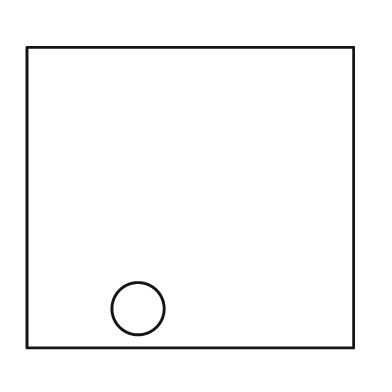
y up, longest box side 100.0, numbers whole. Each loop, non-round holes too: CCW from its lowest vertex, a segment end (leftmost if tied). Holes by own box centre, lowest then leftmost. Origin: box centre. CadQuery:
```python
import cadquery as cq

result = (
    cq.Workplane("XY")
    .moveTo(-50.0, -46.0)
    .lineTo(50.0, -46.0)
    .lineTo(50.0, 46.0)
    .lineTo(-50.0, 46.0)
    .close()
    .moveTo(-16.0, -34.0)
    .circle(8.0)
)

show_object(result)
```